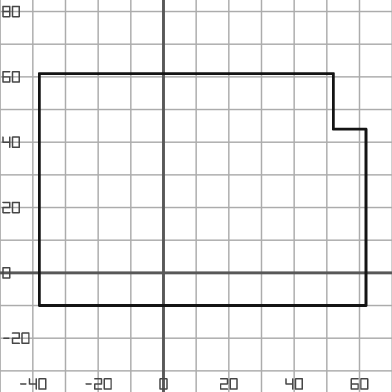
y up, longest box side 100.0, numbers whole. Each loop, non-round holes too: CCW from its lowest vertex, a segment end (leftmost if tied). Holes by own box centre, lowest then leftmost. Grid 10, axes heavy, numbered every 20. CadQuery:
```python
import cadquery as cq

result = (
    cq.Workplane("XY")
    .moveTo(-38.0, -10.0)
    .lineTo(62.0, -10.0)
    .lineTo(62.0, 44.0)
    .lineTo(52.0, 44.0)
    .lineTo(52.0, 61.0)
    .lineTo(-38.0, 61.0)
    .close()
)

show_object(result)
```